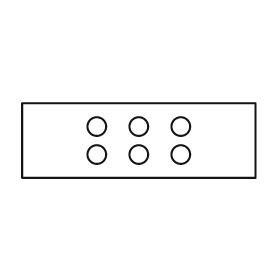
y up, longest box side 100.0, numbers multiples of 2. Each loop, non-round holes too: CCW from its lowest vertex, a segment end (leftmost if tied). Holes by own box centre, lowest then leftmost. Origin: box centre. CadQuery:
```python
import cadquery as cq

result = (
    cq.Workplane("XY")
    .moveTo(-50.0, -16.0)
    .lineTo(50.0, -16.0)
    .lineTo(50.0, 16.0)
    .lineTo(-50.0, 16.0)
    .close()
    .moveTo(-18.0, -6.0)
    .circle(4.0)
    .moveTo(0.0, -6.0)
    .circle(4.0)
    .moveTo(18.0, -6.0)
    .circle(4.0)
    .moveTo(-18.0, 6.0)
    .circle(4.0)
    .moveTo(0.0, 6.0)
    .circle(4.0)
    .moveTo(18.0, 6.0)
    .circle(4.0)
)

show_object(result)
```